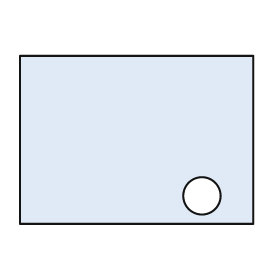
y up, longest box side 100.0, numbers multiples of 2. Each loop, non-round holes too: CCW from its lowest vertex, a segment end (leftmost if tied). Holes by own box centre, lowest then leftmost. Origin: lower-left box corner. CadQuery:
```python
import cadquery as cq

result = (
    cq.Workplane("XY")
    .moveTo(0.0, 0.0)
    .lineTo(100.0, 0.0)
    .lineTo(100.0, 72.0)
    .lineTo(0.0, 72.0)
    .close()
    .moveTo(78.0, 12.0)
    .circle(8.0)
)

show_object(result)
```